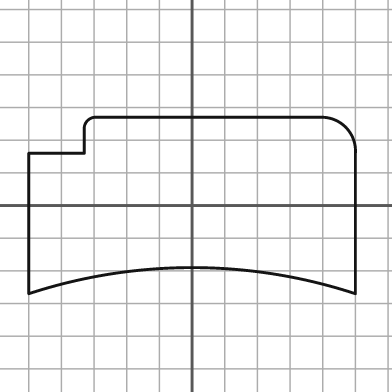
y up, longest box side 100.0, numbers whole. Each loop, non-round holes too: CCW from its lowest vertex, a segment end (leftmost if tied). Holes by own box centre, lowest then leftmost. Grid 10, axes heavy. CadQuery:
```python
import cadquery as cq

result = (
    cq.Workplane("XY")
    .moveTo(-50.0, -27.0)
    .threePointArc((0.0, -19.0), (50.0, -27.0))
    .lineTo(50.0, 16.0)
    .threePointArc((47.0, 24.0), (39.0, 27.0))
    .lineTo(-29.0, 27.0)
    .threePointArc((-32.0, 26.0), (-33.0, 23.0))
    .lineTo(-33.0, 16.0)
    .lineTo(-50.0, 16.0)
    .close()
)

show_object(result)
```